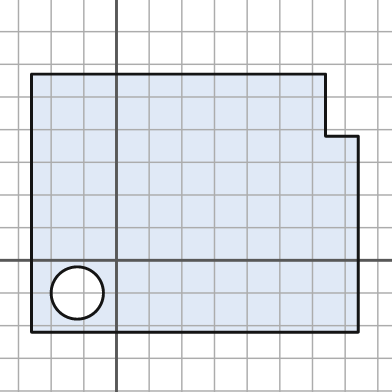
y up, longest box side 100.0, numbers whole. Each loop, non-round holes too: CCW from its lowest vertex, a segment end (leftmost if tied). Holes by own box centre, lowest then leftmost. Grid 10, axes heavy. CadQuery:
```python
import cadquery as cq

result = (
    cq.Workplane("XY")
    .moveTo(-26.0, -22.0)
    .lineTo(74.0, -22.0)
    .lineTo(74.0, 38.0)
    .lineTo(64.0, 38.0)
    .lineTo(64.0, 57.0)
    .lineTo(-26.0, 57.0)
    .close()
    .moveTo(-12.0, -10.0)
    .circle(8.0)
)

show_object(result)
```